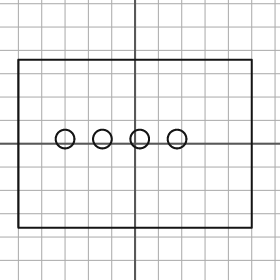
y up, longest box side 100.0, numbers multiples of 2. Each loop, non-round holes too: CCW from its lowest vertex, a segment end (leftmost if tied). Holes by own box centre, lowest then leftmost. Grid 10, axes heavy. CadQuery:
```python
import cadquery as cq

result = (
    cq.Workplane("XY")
    .moveTo(-50.0, -36.0)
    .lineTo(50.0, -36.0)
    .lineTo(50.0, 36.0)
    .lineTo(-50.0, 36.0)
    .close()
    .moveTo(-30.0, 2.0)
    .circle(4.0)
    .moveTo(-14.0, 2.0)
    .circle(4.0)
    .moveTo(2.0, 2.0)
    .circle(4.0)
    .moveTo(18.0, 2.0)
    .circle(4.0)
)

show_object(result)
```